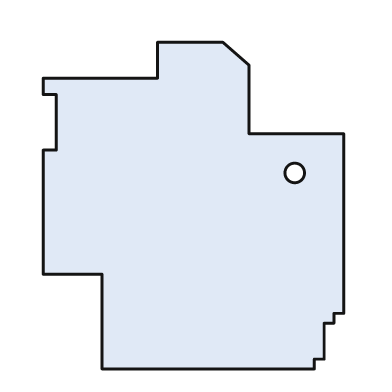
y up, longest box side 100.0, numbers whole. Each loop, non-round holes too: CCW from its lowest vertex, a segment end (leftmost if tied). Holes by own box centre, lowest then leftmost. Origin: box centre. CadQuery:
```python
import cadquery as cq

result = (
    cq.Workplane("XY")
    .moveTo(-28.0, -50.0)
    .lineTo(37.0, -50.0)
    .lineTo(37.0, -47.0)
    .lineTo(40.0, -47.0)
    .lineTo(40.0, -36.0)
    .lineTo(43.0, -36.0)
    .lineTo(43.0, -33.0)
    .lineTo(46.0, -33.0)
    .lineTo(46.0, 22.0)
    .lineTo(17.0, 22.0)
    .lineTo(17.0, 43.0)
    .lineTo(9.0, 50.0)
    .lineTo(-11.0, 50.0)
    .lineTo(-11.0, 39.0)
    .lineTo(-46.0, 39.0)
    .lineTo(-46.0, 34.0)
    .lineTo(-42.0, 34.0)
    .lineTo(-42.0, 17.0)
    .lineTo(-46.0, 17.0)
    .lineTo(-46.0, -21.0)
    .lineTo(-28.0, -21.0)
    .close()
    .moveTo(31.0, 10.0)
    .circle(3.0)
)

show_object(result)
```